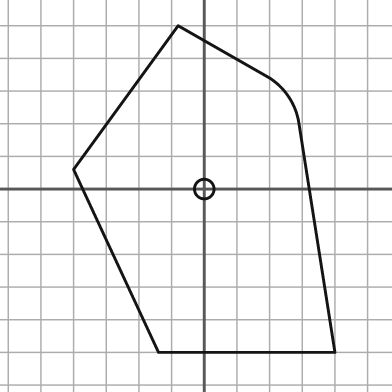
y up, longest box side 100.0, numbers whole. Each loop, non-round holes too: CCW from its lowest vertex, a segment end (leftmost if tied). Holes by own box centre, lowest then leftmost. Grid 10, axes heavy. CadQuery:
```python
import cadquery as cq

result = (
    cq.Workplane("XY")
    .moveTo(-14.0, -50.0)
    .lineTo(40.0, -50.0)
    .lineTo(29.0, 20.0)
    .threePointArc((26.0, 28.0), (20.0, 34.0))
    .lineTo(-8.0, 50.0)
    .lineTo(-40.0, 6.0)
    .close()
    .moveTo(0.0, 0.0)
    .circle(3.0)
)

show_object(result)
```